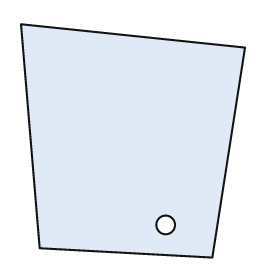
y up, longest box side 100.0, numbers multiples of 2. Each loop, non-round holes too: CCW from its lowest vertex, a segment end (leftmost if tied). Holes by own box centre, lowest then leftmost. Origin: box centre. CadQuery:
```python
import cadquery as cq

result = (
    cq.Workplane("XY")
    .moveTo(34.0, -50.0)
    .lineTo(48.0, 40.0)
    .lineTo(-48.0, 50.0)
    .lineTo(-40.0, -46.0)
    .close()
    .moveTo(14.0, -36.0)
    .circle(4.0)
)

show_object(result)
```